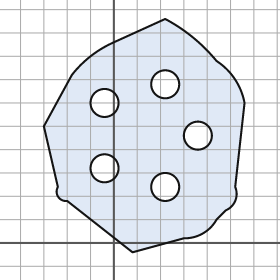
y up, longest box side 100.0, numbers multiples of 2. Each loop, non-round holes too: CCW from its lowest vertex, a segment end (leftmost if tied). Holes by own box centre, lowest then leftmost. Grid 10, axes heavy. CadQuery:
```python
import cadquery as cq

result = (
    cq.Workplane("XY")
    .moveTo(8.0, -4.0)
    .lineTo(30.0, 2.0)
    .threePointArc((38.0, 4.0), (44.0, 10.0))
    .lineTo(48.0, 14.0)
    .threePointArc((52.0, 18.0), (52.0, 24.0))
    .lineTo(56.0, 60.0)
    .threePointArc((52.0, 70.0), (44.0, 78.0))
    .threePointArc((34.0, 88.0), (22.0, 96.0))
    .lineTo(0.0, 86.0)
    .threePointArc((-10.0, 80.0), (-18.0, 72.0))
    .lineTo(-30.0, 50.0)
    .lineTo(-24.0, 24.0)
    .threePointArc((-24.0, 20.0), (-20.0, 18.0))
    .close()
    .moveTo(22.0, 24.0)
    .circle(6.0)
    .moveTo(-4.0, 32.0)
    .circle(6.0)
    .moveTo(36.0, 46.0)
    .circle(6.0)
    .moveTo(-4.0, 60.0)
    .circle(6.0)
    .moveTo(22.0, 68.0)
    .circle(6.0)
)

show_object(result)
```